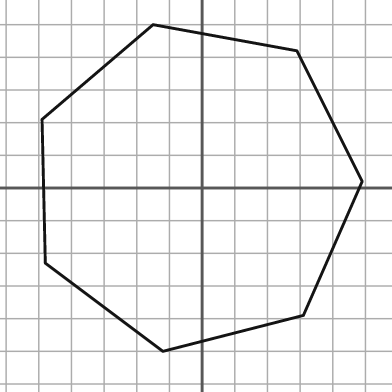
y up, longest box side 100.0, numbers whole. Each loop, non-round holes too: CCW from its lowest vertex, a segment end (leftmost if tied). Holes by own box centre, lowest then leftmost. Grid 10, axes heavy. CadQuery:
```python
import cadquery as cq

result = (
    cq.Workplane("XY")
    .moveTo(-12.0, -50.0)
    .lineTo(31.0, -39.0)
    .lineTo(49.0, 2.0)
    .lineTo(29.0, 42.0)
    .lineTo(-15.0, 50.0)
    .lineTo(-49.0, 21.0)
    .lineTo(-48.0, -23.0)
    .close()
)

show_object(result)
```